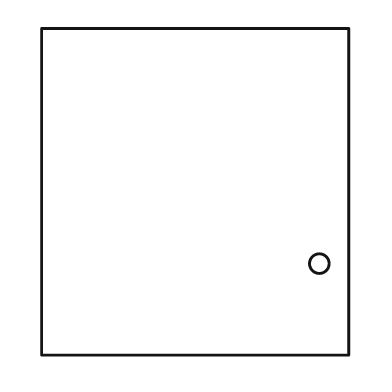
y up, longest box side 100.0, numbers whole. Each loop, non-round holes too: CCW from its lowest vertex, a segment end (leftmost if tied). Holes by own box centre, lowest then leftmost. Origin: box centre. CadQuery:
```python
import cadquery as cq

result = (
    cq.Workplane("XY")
    .moveTo(-47.0, -50.0)
    .lineTo(47.0, -50.0)
    .lineTo(47.0, 50.0)
    .lineTo(-47.0, 50.0)
    .close()
    .moveTo(38.0, -22.0)
    .circle(3.0)
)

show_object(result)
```